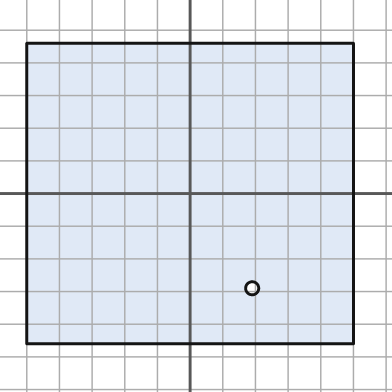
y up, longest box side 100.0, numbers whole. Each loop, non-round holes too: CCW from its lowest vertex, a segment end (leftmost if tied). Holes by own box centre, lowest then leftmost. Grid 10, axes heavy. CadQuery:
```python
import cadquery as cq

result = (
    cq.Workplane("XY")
    .moveTo(-50.0, -46.0)
    .lineTo(50.0, -46.0)
    .lineTo(50.0, 46.0)
    .lineTo(-50.0, 46.0)
    .close()
    .moveTo(19.0, -29.0)
    .circle(2.0)
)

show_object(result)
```